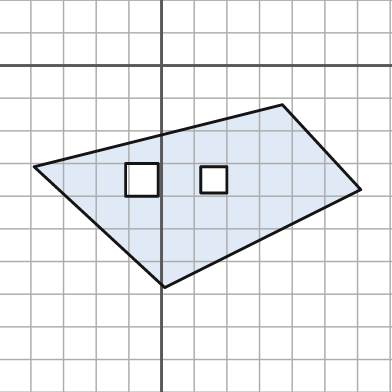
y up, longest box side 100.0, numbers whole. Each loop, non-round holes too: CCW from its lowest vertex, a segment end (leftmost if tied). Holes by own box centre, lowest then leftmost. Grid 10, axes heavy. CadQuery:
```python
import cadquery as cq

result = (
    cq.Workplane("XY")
    .moveTo(1.0, -68.0)
    .lineTo(61.0, -38.0)
    .lineTo(37.0, -12.0)
    .lineTo(-39.0, -31.0)
    .close()
    .moveTo(-11.0, -40.0)
    .lineTo(-1.0, -40.0)
    .lineTo(-1.0, -30.0)
    .lineTo(-11.0, -30.0)
    .close()
    .moveTo(12.0, -39.0)
    .lineTo(20.0, -39.0)
    .lineTo(20.0, -31.0)
    .lineTo(12.0, -31.0)
    .close()
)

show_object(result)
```